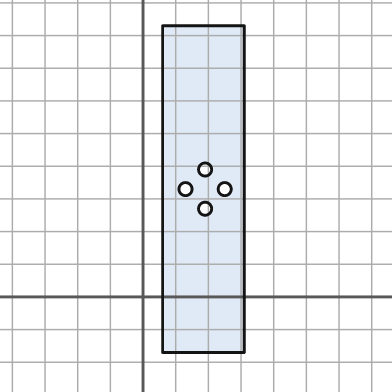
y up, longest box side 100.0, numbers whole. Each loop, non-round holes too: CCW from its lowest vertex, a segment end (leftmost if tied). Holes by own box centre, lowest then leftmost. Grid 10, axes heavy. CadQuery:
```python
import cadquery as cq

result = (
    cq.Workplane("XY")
    .moveTo(6.0, -17.0)
    .lineTo(31.0, -17.0)
    .lineTo(31.0, 83.0)
    .lineTo(6.0, 83.0)
    .close()
    .moveTo(19.0, 27.0)
    .circle(2.0)
    .moveTo(13.0, 33.0)
    .circle(2.0)
    .moveTo(25.0, 33.0)
    .circle(2.0)
    .moveTo(19.0, 39.0)
    .circle(2.0)
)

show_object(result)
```